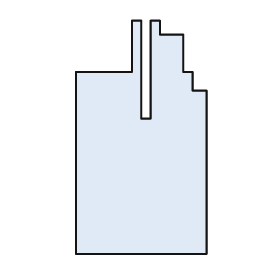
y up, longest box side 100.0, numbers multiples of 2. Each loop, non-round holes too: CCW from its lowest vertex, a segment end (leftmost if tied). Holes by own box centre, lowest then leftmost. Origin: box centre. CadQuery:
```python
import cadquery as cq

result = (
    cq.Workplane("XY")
    .moveTo(-28.0, -50.0)
    .lineTo(28.0, -50.0)
    .lineTo(28.0, 20.0)
    .lineTo(22.0, 20.0)
    .lineTo(22.0, 28.0)
    .lineTo(18.0, 28.0)
    .lineTo(18.0, 44.0)
    .lineTo(8.0, 44.0)
    .lineTo(8.0, 50.0)
    .lineTo(4.0, 50.0)
    .lineTo(4.0, 8.0)
    .lineTo(0.0, 8.0)
    .lineTo(0.0, 50.0)
    .lineTo(-4.0, 50.0)
    .lineTo(-4.0, 28.0)
    .lineTo(-28.0, 28.0)
    .close()
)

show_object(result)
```